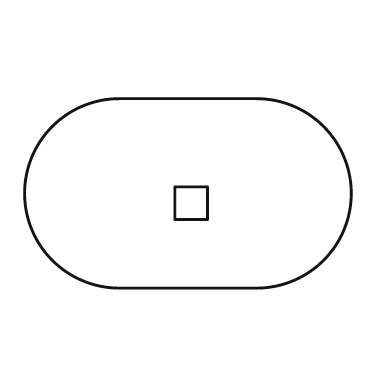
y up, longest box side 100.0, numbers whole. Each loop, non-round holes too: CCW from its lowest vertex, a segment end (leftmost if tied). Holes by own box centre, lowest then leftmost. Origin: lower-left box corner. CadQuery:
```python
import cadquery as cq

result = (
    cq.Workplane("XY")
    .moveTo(29.0, 0.0)
    .lineTo(71.0, 0.0)
    .threePointArc((100.0, 29.0), (71.0, 58.0))
    .lineTo(29.0, 58.0)
    .threePointArc((0.0, 29.0), (29.0, 0.0))
    .close()
    .moveTo(46.0, 21.0)
    .lineTo(56.0, 21.0)
    .lineTo(56.0, 31.0)
    .lineTo(46.0, 31.0)
    .close()
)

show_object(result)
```